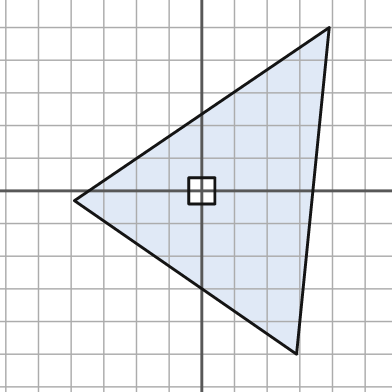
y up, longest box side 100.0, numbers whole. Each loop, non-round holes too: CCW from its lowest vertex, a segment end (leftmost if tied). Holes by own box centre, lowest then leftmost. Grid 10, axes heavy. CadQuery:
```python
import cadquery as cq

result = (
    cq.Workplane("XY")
    .moveTo(29.0, -50.0)
    .lineTo(39.0, 50.0)
    .lineTo(-39.0, -3.0)
    .close()
    .moveTo(-4.0, -4.0)
    .lineTo(4.0, -4.0)
    .lineTo(4.0, 4.0)
    .lineTo(-4.0, 4.0)
    .close()
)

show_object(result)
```